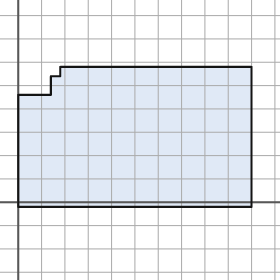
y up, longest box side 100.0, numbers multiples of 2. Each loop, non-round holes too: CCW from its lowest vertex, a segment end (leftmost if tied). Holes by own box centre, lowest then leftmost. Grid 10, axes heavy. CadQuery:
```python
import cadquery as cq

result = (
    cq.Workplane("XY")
    .moveTo(0.0, -2.0)
    .lineTo(100.0, -2.0)
    .lineTo(100.0, 58.0)
    .lineTo(18.0, 58.0)
    .lineTo(18.0, 54.0)
    .lineTo(14.0, 54.0)
    .lineTo(14.0, 46.0)
    .lineTo(0.0, 46.0)
    .close()
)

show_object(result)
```